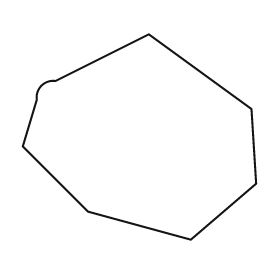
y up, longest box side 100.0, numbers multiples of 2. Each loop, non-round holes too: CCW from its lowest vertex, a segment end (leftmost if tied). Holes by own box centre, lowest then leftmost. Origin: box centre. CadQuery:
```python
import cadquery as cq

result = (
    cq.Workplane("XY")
    .moveTo(22.0, -44.0)
    .lineTo(50.0, -20.0)
    .lineTo(48.0, 12.0)
    .lineTo(4.0, 44.0)
    .lineTo(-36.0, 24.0)
    .threePointArc((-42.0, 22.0), (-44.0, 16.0))
    .lineTo(-50.0, -4.0)
    .lineTo(-22.0, -32.0)
    .close()
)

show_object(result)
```